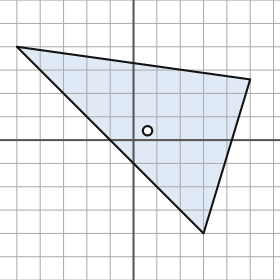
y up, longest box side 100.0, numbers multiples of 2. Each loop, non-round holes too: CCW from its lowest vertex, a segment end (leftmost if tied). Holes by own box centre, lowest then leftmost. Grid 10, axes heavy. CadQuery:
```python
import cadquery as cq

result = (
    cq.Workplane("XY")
    .moveTo(30.0, -40.0)
    .lineTo(50.0, 26.0)
    .lineTo(-50.0, 40.0)
    .close()
    .moveTo(6.0, 4.0)
    .circle(2.0)
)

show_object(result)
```